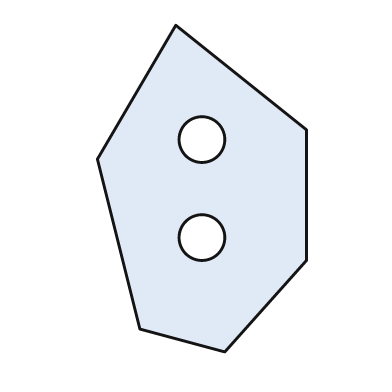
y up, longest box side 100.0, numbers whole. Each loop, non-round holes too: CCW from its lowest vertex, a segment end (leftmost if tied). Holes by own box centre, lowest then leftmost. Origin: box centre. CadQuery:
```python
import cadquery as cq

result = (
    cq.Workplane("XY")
    .moveTo(7.0, -50.0)
    .lineTo(32.0, -22.0)
    .lineTo(32.0, 18.0)
    .lineTo(-8.0, 50.0)
    .lineTo(-32.0, 9.0)
    .lineTo(-19.0, -43.0)
    .close()
    .moveTo(0.0, -15.0)
    .circle(7.0)
    .moveTo(0.0, 15.0)
    .circle(7.0)
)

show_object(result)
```